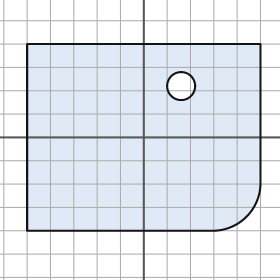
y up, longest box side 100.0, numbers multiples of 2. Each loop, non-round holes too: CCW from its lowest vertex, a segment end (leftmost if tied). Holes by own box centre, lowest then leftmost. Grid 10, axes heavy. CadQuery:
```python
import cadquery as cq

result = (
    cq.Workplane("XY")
    .moveTo(-50.0, -40.0)
    .lineTo(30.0, -40.0)
    .threePointArc((44.0, -34.0), (50.0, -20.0))
    .lineTo(50.0, 40.0)
    .lineTo(-50.0, 40.0)
    .close()
    .moveTo(16.0, 22.0)
    .circle(6.0)
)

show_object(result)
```